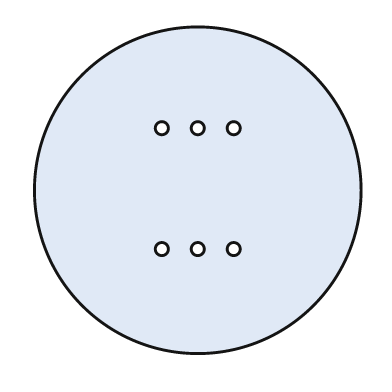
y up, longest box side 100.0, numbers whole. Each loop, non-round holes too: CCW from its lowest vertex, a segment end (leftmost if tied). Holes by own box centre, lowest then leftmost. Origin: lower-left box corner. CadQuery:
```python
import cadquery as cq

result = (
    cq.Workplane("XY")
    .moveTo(50.0, 50.0)
    .circle(50.0)
    .moveTo(39.0, 32.0)
    .circle(2.0)
    .moveTo(50.0, 32.0)
    .circle(2.0)
    .moveTo(61.0, 32.0)
    .circle(2.0)
    .moveTo(39.0, 69.0)
    .circle(2.0)
    .moveTo(50.0, 69.0)
    .circle(2.0)
    .moveTo(61.0, 69.0)
    .circle(2.0)
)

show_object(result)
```